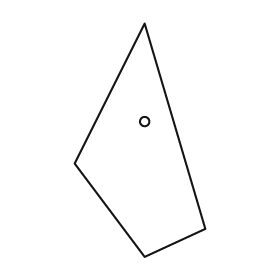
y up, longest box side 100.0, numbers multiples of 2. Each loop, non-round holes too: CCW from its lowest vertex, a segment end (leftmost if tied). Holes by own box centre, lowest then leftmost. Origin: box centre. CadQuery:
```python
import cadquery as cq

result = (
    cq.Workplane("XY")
    .moveTo(2.0, -50.0)
    .lineTo(28.0, -38.0)
    .lineTo(2.0, 50.0)
    .lineTo(-28.0, -10.0)
    .close()
    .moveTo(2.0, 8.0)
    .circle(2.0)
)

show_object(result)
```